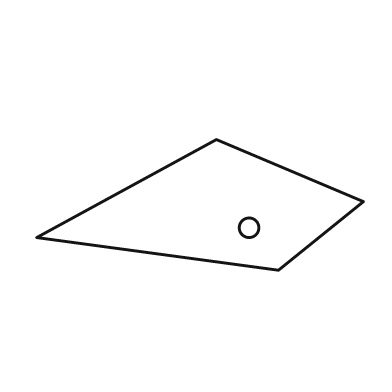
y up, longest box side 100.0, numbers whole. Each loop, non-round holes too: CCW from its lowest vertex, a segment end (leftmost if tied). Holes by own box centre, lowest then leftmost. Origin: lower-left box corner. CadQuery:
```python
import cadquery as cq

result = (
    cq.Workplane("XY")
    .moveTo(74.0, 0.0)
    .lineTo(100.0, 21.0)
    .lineTo(55.0, 40.0)
    .lineTo(0.0, 10.0)
    .close()
    .moveTo(65.0, 13.0)
    .circle(3.0)
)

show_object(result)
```